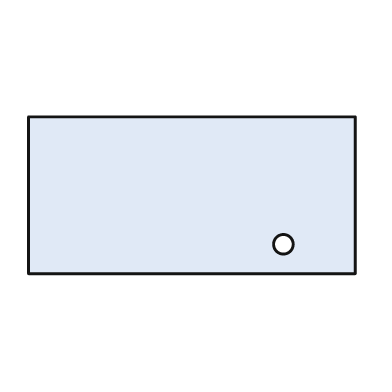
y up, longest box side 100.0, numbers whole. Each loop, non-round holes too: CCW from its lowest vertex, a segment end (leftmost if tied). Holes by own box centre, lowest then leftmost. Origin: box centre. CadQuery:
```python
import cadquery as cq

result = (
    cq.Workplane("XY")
    .moveTo(-50.0, -24.0)
    .lineTo(50.0, -24.0)
    .lineTo(50.0, 24.0)
    .lineTo(-50.0, 24.0)
    .close()
    .moveTo(28.0, -15.0)
    .circle(3.0)
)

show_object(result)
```